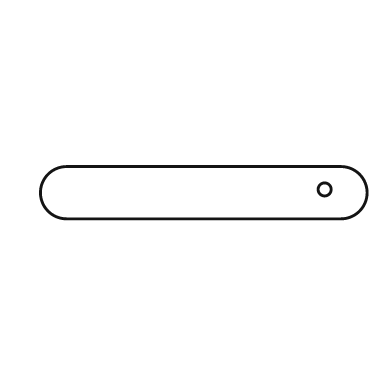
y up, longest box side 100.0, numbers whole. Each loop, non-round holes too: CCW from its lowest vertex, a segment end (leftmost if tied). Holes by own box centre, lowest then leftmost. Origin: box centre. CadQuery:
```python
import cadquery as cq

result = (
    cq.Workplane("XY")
    .moveTo(-42.0, -8.0)
    .lineTo(42.0, -8.0)
    .threePointArc((50.0, 0.0), (42.0, 8.0))
    .lineTo(-42.0, 8.0)
    .threePointArc((-50.0, 0.0), (-42.0, -8.0))
    .close()
    .moveTo(37.0, 1.0)
    .circle(2.0)
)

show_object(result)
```